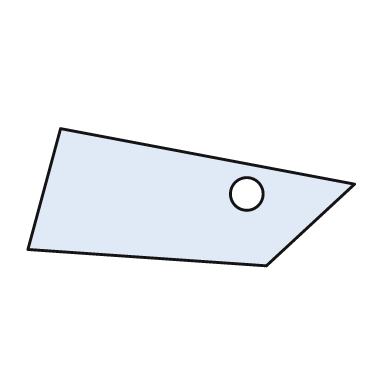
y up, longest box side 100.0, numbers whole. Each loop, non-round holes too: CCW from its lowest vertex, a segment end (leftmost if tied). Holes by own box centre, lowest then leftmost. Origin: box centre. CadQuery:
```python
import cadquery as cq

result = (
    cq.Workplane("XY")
    .moveTo(23.0, -21.0)
    .lineTo(50.0, 4.0)
    .lineTo(-40.0, 21.0)
    .lineTo(-50.0, -16.0)
    .close()
    .moveTo(17.0, 1.0)
    .circle(5.0)
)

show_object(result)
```